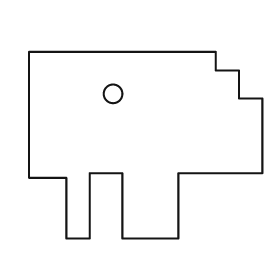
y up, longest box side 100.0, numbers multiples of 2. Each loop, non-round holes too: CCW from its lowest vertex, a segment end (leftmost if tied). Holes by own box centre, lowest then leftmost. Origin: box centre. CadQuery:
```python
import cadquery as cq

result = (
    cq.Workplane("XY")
    .moveTo(-34.0, -40.0)
    .lineTo(-24.0, -40.0)
    .lineTo(-24.0, -12.0)
    .lineTo(-10.0, -12.0)
    .lineTo(-10.0, -40.0)
    .lineTo(14.0, -40.0)
    .lineTo(14.0, -12.0)
    .lineTo(50.0, -12.0)
    .lineTo(50.0, 20.0)
    .lineTo(40.0, 20.0)
    .lineTo(40.0, 32.0)
    .lineTo(30.0, 32.0)
    .lineTo(30.0, 40.0)
    .lineTo(-50.0, 40.0)
    .lineTo(-50.0, -14.0)
    .lineTo(-34.0, -14.0)
    .close()
    .moveTo(-14.0, 22.0)
    .circle(4.0)
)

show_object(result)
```